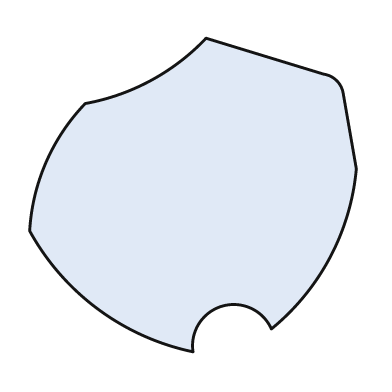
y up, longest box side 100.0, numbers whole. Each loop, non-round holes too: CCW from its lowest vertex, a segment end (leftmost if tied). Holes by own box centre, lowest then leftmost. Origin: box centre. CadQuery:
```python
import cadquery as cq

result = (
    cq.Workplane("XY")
    .moveTo(0.0, -48.0)
    .threePointArc((9.0, -34.0), (24.0, -41.0))
    .threePointArc((42.0, -19.0), (50.0, 8.0))
    .lineTo(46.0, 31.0)
    .threePointArc((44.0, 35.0), (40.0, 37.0))
    .lineTo(4.0, 48.0)
    .threePointArc((-13.0, 35.0), (-33.0, 28.0))
    .threePointArc((-45.0, 10.0), (-50.0, -11.0))
    .threePointArc((-29.0, -35.0), (0.0, -48.0))
    .close()
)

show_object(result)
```